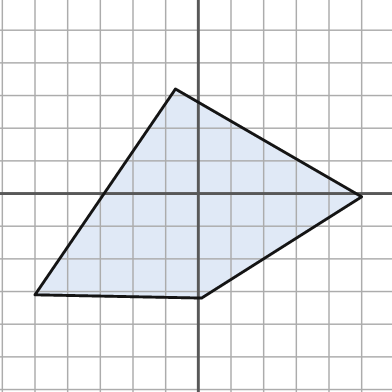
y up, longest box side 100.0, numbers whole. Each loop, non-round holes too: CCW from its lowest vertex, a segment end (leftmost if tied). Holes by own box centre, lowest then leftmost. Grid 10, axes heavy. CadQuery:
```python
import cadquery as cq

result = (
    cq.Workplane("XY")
    .moveTo(1.0, -32.0)
    .lineTo(50.0, -1.0)
    .lineTo(-7.0, 32.0)
    .lineTo(-50.0, -31.0)
    .close()
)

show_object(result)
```